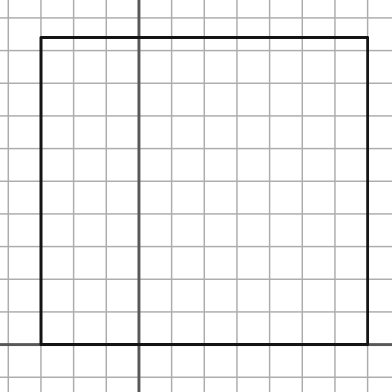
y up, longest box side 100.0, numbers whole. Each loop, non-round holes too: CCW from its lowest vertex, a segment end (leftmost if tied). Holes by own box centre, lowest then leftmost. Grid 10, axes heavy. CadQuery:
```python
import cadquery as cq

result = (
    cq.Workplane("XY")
    .moveTo(-30.0, 0.0)
    .lineTo(70.0, 0.0)
    .lineTo(70.0, 94.0)
    .lineTo(-30.0, 94.0)
    .close()
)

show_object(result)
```